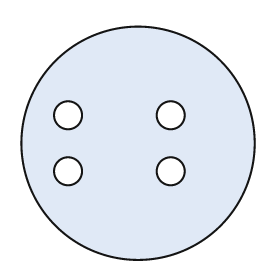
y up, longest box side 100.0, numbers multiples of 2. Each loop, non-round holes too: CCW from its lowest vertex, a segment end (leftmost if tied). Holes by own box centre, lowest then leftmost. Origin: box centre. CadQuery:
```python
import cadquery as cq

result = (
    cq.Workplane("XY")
    .moveTo(0.0, 0.0)
    .circle(50.0)
    .moveTo(-30.0, -12.0)
    .circle(6.0)
    .moveTo(14.0, -12.0)
    .circle(6.0)
    .moveTo(-30.0, 12.0)
    .circle(6.0)
    .moveTo(14.0, 12.0)
    .circle(6.0)
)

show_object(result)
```